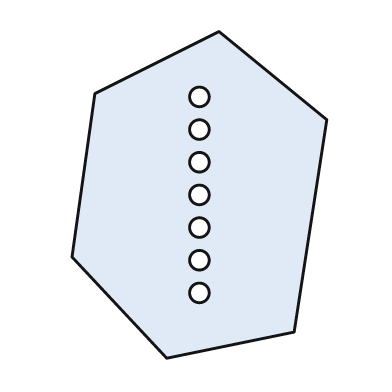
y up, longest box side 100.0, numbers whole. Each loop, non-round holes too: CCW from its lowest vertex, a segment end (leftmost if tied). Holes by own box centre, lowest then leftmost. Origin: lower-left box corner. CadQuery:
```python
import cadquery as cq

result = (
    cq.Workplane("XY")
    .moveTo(29.0, 0.0)
    .lineTo(68.0, 8.0)
    .lineTo(78.0, 73.0)
    .lineTo(45.0, 100.0)
    .lineTo(7.0, 81.0)
    .lineTo(0.0, 31.0)
    .close()
    .moveTo(39.0, 20.0)
    .circle(3.0)
    .moveTo(39.0, 30.0)
    .circle(3.0)
    .moveTo(39.0, 40.0)
    .circle(3.0)
    .moveTo(39.0, 50.0)
    .circle(3.0)
    .moveTo(39.0, 60.0)
    .circle(3.0)
    .moveTo(39.0, 70.0)
    .circle(3.0)
    .moveTo(39.0, 80.0)
    .circle(3.0)
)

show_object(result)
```